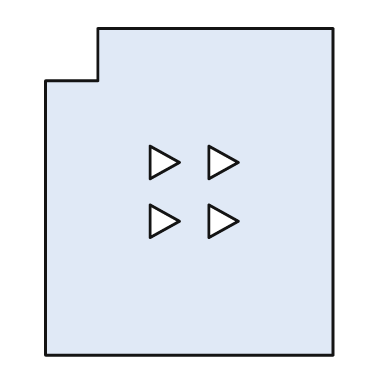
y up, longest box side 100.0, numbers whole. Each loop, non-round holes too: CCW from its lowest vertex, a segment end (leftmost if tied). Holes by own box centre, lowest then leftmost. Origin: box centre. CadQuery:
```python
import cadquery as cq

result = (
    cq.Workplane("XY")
    .moveTo(-44.0, -50.0)
    .lineTo(44.0, -50.0)
    .lineTo(44.0, 50.0)
    .lineTo(-28.0, 50.0)
    .lineTo(-28.0, 34.0)
    .lineTo(-44.0, 34.0)
    .close()
    .moveTo(-12.0, -14.0)
    .lineTo(-3.0, -9.0)
    .lineTo(-12.0, -4.0)
    .close()
    .moveTo(6.0, -14.0)
    .lineTo(15.0, -9.0)
    .lineTo(6.0, -4.0)
    .close()
    .moveTo(-12.0, 4.0)
    .lineTo(-3.0, 9.0)
    .lineTo(-12.0, 14.0)
    .close()
    .moveTo(6.0, 4.0)
    .lineTo(15.0, 9.0)
    .lineTo(6.0, 14.0)
    .close()
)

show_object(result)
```